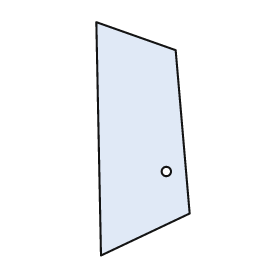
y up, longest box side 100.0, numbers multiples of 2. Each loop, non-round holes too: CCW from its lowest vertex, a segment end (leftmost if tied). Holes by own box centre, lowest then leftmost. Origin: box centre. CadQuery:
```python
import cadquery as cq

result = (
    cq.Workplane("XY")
    .moveTo(-18.0, -50.0)
    .lineTo(20.0, -32.0)
    .lineTo(14.0, 38.0)
    .lineTo(-20.0, 50.0)
    .close()
    .moveTo(10.0, -14.0)
    .circle(2.0)
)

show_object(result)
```